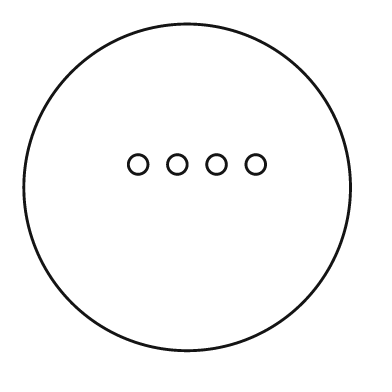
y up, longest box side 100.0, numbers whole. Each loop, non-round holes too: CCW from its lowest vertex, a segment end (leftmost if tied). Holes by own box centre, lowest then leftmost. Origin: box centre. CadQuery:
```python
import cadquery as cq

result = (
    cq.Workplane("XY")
    .moveTo(0.0, 0.0)
    .circle(50.0)
    .moveTo(-15.0, 7.0)
    .circle(3.0)
    .moveTo(-3.0, 7.0)
    .circle(3.0)
    .moveTo(9.0, 7.0)
    .circle(3.0)
    .moveTo(21.0, 7.0)
    .circle(3.0)
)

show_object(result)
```